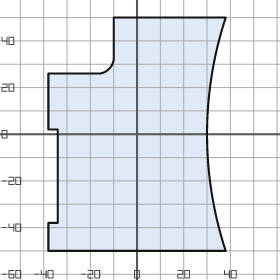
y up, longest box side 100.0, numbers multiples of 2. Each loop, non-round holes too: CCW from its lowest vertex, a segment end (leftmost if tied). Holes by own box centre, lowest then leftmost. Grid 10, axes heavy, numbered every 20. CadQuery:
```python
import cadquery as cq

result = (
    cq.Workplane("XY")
    .moveTo(-38.0, -50.0)
    .lineTo(38.0, -50.0)
    .threePointArc((30.0, 0.0), (38.0, 50.0))
    .lineTo(-10.0, 50.0)
    .lineTo(-10.0, 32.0)
    .threePointArc((-12.0, 28.0), (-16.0, 26.0))
    .lineTo(-38.0, 26.0)
    .lineTo(-38.0, 2.0)
    .lineTo(-34.0, 2.0)
    .lineTo(-34.0, -38.0)
    .lineTo(-38.0, -38.0)
    .close()
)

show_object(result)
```